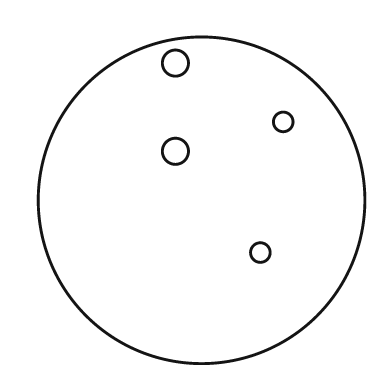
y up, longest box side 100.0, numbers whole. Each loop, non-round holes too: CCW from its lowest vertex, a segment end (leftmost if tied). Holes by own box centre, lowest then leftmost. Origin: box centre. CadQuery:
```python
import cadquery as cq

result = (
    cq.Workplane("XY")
    .moveTo(0.0, 0.0)
    .circle(50.0)
    .moveTo(18.0, -16.0)
    .circle(3.0)
    .moveTo(-8.0, 15.0)
    .circle(4.0)
    .moveTo(25.0, 24.0)
    .circle(3.0)
    .moveTo(-8.0, 42.0)
    .circle(4.0)
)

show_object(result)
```